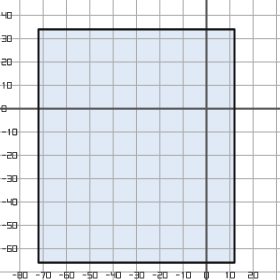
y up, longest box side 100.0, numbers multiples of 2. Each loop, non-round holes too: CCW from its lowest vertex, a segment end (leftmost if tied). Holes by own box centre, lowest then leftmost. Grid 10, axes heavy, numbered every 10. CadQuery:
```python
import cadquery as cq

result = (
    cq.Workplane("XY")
    .moveTo(-72.0, -66.0)
    .lineTo(12.0, -66.0)
    .lineTo(12.0, 34.0)
    .lineTo(-72.0, 34.0)
    .close()
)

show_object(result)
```